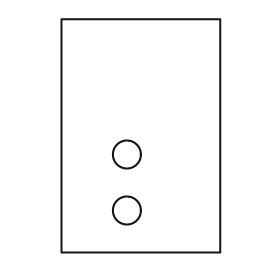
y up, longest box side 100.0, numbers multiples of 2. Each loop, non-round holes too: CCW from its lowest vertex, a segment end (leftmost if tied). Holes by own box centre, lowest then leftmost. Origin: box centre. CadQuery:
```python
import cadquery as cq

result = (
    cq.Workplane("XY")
    .moveTo(-34.0, -50.0)
    .lineTo(34.0, -50.0)
    .lineTo(34.0, 50.0)
    .lineTo(-34.0, 50.0)
    .close()
    .moveTo(-6.0, -32.0)
    .circle(6.0)
    .moveTo(-6.0, -8.0)
    .circle(6.0)
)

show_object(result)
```